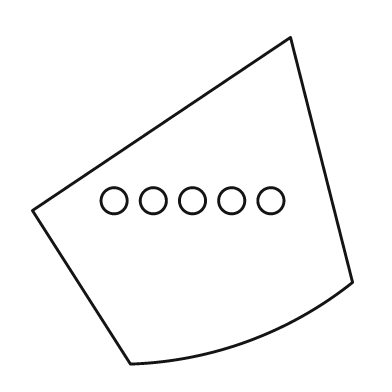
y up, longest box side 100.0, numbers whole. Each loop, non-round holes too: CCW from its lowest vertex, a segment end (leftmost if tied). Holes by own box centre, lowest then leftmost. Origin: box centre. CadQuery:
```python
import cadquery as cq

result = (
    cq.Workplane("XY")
    .moveTo(-19.0, -50.0)
    .threePointArc((17.0, -43.0), (49.0, -25.0))
    .lineTo(30.0, 50.0)
    .lineTo(-49.0, -3.0)
    .close()
    .moveTo(-24.0, 0.0)
    .circle(4.0)
    .moveTo(-12.0, 0.0)
    .circle(4.0)
    .moveTo(0.0, 0.0)
    .circle(4.0)
    .moveTo(12.0, 0.0)
    .circle(4.0)
    .moveTo(24.0, 0.0)
    .circle(4.0)
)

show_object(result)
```